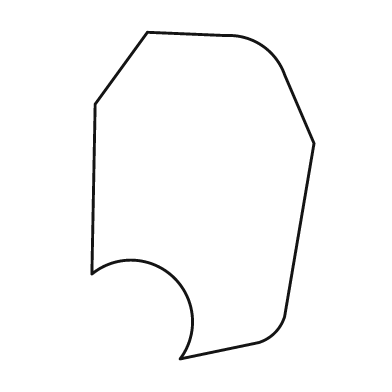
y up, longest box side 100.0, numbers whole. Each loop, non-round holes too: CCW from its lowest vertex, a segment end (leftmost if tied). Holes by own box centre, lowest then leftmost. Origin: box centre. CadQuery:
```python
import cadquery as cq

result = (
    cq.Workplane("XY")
    .moveTo(-7.0, -50.0)
    .lineTo(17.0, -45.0)
    .threePointArc((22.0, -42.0), (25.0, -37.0))
    .lineTo(34.0, 16.0)
    .lineTo(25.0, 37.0)
    .threePointArc((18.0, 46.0), (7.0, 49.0))
    .lineTo(-17.0, 50.0)
    .lineTo(-33.0, 28.0)
    .lineTo(-34.0, -24.0)
    .threePointArc((-9.0, -25.0), (-7.0, -50.0))
    .close()
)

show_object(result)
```